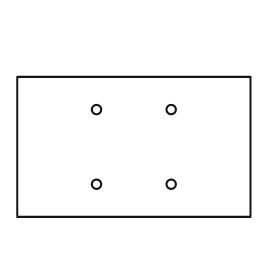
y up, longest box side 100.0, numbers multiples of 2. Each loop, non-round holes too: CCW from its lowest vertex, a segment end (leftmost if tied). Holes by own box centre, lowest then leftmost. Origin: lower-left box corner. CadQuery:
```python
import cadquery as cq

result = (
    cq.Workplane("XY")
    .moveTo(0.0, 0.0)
    .lineTo(100.0, 0.0)
    .lineTo(100.0, 60.0)
    .lineTo(0.0, 60.0)
    .close()
    .moveTo(34.0, 14.0)
    .circle(2.0)
    .moveTo(66.0, 14.0)
    .circle(2.0)
    .moveTo(34.0, 46.0)
    .circle(2.0)
    .moveTo(66.0, 46.0)
    .circle(2.0)
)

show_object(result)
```